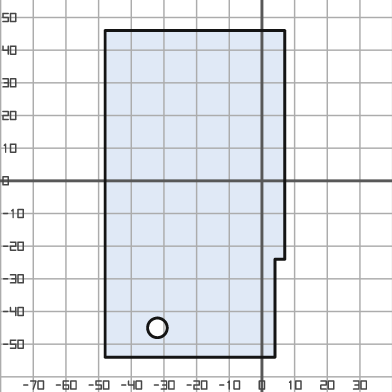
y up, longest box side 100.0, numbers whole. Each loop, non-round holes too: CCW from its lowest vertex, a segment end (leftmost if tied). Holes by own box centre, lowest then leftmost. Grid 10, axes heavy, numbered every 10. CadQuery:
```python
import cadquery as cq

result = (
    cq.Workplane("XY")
    .moveTo(-48.0, -54.0)
    .lineTo(4.0, -54.0)
    .lineTo(4.0, -24.0)
    .lineTo(7.0, -24.0)
    .lineTo(7.0, 46.0)
    .lineTo(-48.0, 46.0)
    .close()
    .moveTo(-32.0, -45.0)
    .circle(3.0)
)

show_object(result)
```